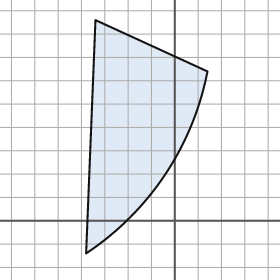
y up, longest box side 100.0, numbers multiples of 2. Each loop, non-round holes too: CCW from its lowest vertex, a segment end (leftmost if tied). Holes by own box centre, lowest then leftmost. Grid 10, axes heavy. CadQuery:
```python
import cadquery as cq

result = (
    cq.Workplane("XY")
    .moveTo(-38.0, -14.0)
    .threePointArc((-4.0, 20.0), (14.0, 64.0))
    .lineTo(-34.0, 86.0)
    .close()
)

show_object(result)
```